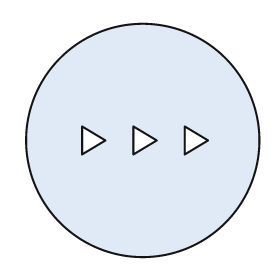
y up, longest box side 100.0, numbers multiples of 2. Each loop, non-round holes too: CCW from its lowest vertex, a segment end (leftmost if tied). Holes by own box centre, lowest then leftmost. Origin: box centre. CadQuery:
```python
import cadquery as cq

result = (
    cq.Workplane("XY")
    .moveTo(0.0, 0.0)
    .circle(50.0)
    .moveTo(-26.0, -6.0)
    .lineTo(-16.0, 0.0)
    .lineTo(-26.0, 6.0)
    .close()
    .moveTo(-4.0, -6.0)
    .lineTo(6.0, 0.0)
    .lineTo(-4.0, 6.0)
    .close()
    .moveTo(18.0, -6.0)
    .lineTo(28.0, 0.0)
    .lineTo(18.0, 6.0)
    .close()
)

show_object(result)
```